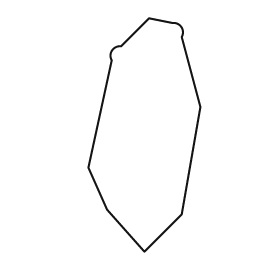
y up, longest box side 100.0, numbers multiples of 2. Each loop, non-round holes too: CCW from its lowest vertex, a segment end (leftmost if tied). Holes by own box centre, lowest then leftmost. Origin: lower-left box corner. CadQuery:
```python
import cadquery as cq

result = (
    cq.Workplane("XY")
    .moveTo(24.0, 0.0)
    .lineTo(40.0, 16.0)
    .lineTo(48.0, 62.0)
    .lineTo(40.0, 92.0)
    .threePointArc((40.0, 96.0), (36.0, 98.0))
    .lineTo(26.0, 100.0)
    .lineTo(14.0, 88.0)
    .threePointArc((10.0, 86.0), (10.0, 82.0))
    .lineTo(0.0, 36.0)
    .lineTo(8.0, 18.0)
    .close()
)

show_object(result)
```